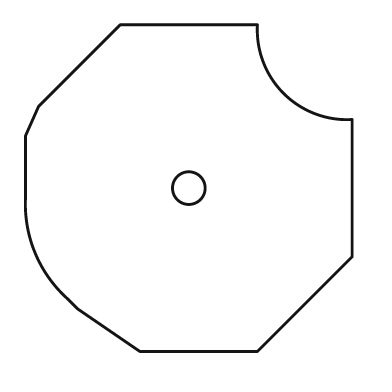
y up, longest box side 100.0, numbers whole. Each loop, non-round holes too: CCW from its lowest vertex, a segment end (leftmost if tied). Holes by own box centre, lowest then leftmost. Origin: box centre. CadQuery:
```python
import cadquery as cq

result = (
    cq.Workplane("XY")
    .moveTo(-15.0, -50.0)
    .lineTo(21.0, -50.0)
    .lineTo(50.0, -21.0)
    .lineTo(50.0, 21.0)
    .threePointArc((29.0, 29.0), (21.0, 50.0))
    .lineTo(-21.0, 50.0)
    .lineTo(-46.0, 25.0)
    .lineTo(-50.0, 16.0)
    .lineTo(-50.0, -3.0)
    .threePointArc((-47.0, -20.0), (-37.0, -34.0))
    .lineTo(-34.0, -37.0)
    .close()
    .moveTo(0.0, 0.0)
    .circle(5.0)
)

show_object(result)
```